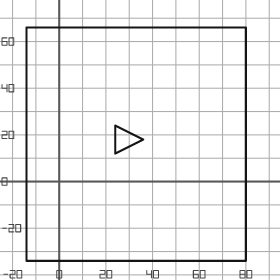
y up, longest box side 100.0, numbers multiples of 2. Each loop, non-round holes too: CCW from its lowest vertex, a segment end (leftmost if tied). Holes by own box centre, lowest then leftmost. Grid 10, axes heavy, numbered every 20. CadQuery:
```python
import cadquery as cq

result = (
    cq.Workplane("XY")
    .moveTo(-14.0, -34.0)
    .lineTo(80.0, -34.0)
    .lineTo(80.0, 66.0)
    .lineTo(-14.0, 66.0)
    .close()
    .moveTo(24.0, 12.0)
    .lineTo(36.0, 18.0)
    .lineTo(24.0, 24.0)
    .close()
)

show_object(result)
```